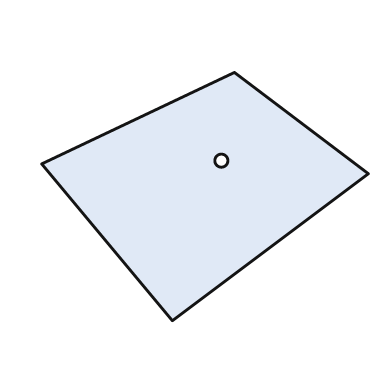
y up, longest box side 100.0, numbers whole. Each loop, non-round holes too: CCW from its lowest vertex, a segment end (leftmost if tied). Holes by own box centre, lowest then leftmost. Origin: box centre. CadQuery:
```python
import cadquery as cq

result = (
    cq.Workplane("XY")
    .moveTo(-10.0, -38.0)
    .lineTo(50.0, 7.0)
    .lineTo(9.0, 38.0)
    .lineTo(-50.0, 10.0)
    .close()
    .moveTo(5.0, 11.0)
    .circle(2.0)
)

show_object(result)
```